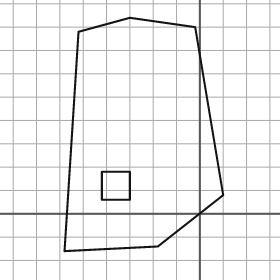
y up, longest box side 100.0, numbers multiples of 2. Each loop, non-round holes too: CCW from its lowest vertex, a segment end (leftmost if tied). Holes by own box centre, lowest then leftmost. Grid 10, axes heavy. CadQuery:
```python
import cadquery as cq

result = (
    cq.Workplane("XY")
    .moveTo(-58.0, -16.0)
    .lineTo(-18.0, -14.0)
    .lineTo(10.0, 8.0)
    .lineTo(-2.0, 80.0)
    .lineTo(-30.0, 84.0)
    .lineTo(-52.0, 78.0)
    .close()
    .moveTo(-42.0, 6.0)
    .lineTo(-30.0, 6.0)
    .lineTo(-30.0, 18.0)
    .lineTo(-42.0, 18.0)
    .close()
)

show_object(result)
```